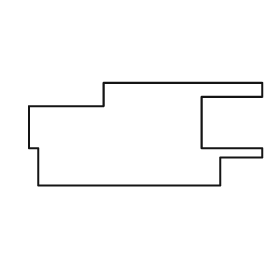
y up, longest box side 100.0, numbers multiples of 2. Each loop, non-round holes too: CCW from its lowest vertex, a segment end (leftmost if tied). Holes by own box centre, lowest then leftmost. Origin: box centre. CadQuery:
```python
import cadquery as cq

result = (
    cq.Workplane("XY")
    .moveTo(-46.0, -22.0)
    .lineTo(32.0, -22.0)
    .lineTo(32.0, -10.0)
    .lineTo(50.0, -10.0)
    .lineTo(50.0, -6.0)
    .lineTo(24.0, -6.0)
    .lineTo(24.0, 16.0)
    .lineTo(50.0, 16.0)
    .lineTo(50.0, 22.0)
    .lineTo(-18.0, 22.0)
    .lineTo(-18.0, 12.0)
    .lineTo(-50.0, 12.0)
    .lineTo(-50.0, -6.0)
    .lineTo(-46.0, -6.0)
    .close()
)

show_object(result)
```